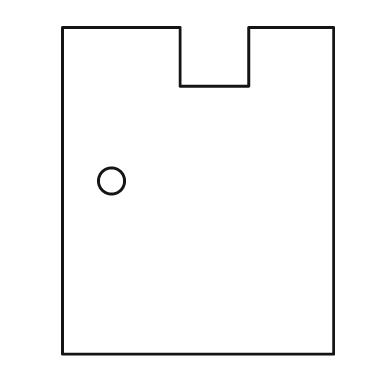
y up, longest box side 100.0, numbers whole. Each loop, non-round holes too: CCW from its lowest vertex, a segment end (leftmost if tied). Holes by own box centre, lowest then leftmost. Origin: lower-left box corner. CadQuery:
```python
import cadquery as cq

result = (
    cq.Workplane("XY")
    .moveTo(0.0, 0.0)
    .lineTo(83.0, 0.0)
    .lineTo(83.0, 100.0)
    .lineTo(57.0, 100.0)
    .lineTo(57.0, 82.0)
    .lineTo(36.0, 82.0)
    .lineTo(36.0, 100.0)
    .lineTo(0.0, 100.0)
    .close()
    .moveTo(15.0, 53.0)
    .circle(4.0)
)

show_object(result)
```